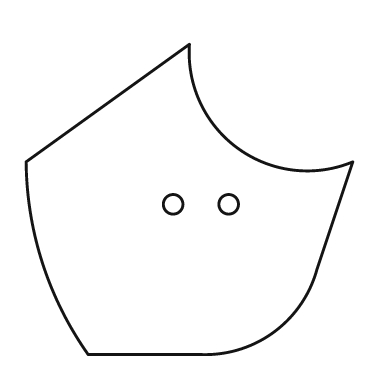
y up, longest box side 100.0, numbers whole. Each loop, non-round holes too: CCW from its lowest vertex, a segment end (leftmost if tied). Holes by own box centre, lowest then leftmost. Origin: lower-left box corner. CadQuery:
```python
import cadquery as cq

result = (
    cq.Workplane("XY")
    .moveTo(19.0, 0.0)
    .lineTo(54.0, 0.0)
    .threePointArc((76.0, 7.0), (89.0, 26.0))
    .lineTo(100.0, 59.0)
    .threePointArc((65.0, 63.0), (50.0, 95.0))
    .lineTo(0.0, 59.0)
    .threePointArc((5.0, 28.0), (19.0, 0.0))
    .close()
    .moveTo(45.0, 46.0)
    .circle(3.0)
    .moveTo(62.0, 46.0)
    .circle(3.0)
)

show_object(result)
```